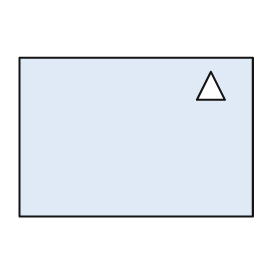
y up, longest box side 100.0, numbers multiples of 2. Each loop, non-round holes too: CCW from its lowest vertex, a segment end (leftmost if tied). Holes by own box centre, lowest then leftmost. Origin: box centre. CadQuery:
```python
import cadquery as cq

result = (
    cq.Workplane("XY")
    .moveTo(-50.0, -34.0)
    .lineTo(50.0, -34.0)
    .lineTo(50.0, 34.0)
    .lineTo(-50.0, 34.0)
    .close()
    .moveTo(26.0, 16.0)
    .lineTo(38.0, 16.0)
    .lineTo(32.0, 28.0)
    .close()
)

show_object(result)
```